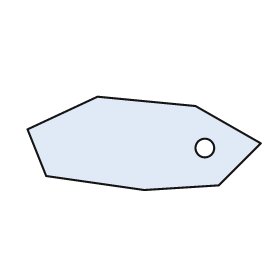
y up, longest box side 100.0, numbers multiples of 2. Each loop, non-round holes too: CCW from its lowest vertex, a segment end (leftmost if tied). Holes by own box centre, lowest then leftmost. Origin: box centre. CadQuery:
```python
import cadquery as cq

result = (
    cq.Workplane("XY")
    .moveTo(0.0, -20.0)
    .lineTo(32.0, -18.0)
    .lineTo(50.0, 0.0)
    .lineTo(22.0, 16.0)
    .lineTo(-20.0, 20.0)
    .lineTo(-50.0, 6.0)
    .lineTo(-42.0, -14.0)
    .close()
    .moveTo(26.0, -2.0)
    .circle(4.0)
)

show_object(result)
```